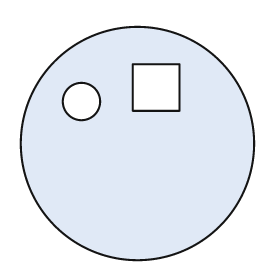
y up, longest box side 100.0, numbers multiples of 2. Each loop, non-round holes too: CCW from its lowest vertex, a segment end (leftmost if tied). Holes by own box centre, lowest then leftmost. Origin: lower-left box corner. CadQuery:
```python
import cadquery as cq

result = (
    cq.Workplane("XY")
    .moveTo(50.0, 50.0)
    .circle(50.0)
    .moveTo(26.0, 68.0)
    .circle(8.0)
    .moveTo(48.0, 64.0)
    .lineTo(68.0, 64.0)
    .lineTo(68.0, 84.0)
    .lineTo(48.0, 84.0)
    .close()
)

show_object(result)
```